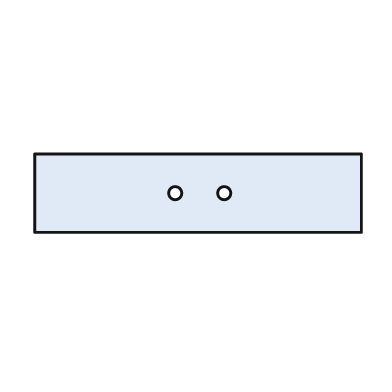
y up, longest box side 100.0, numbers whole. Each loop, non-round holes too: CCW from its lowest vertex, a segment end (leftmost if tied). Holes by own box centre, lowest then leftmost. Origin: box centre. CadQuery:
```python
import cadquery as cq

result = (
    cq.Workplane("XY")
    .moveTo(-50.0, -12.0)
    .lineTo(50.0, -12.0)
    .lineTo(50.0, 12.0)
    .lineTo(-50.0, 12.0)
    .close()
    .moveTo(-7.0, 0.0)
    .circle(2.0)
    .moveTo(8.0, 0.0)
    .circle(2.0)
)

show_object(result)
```